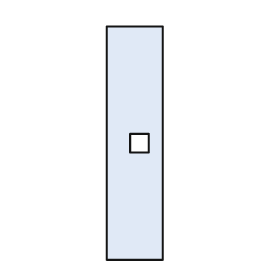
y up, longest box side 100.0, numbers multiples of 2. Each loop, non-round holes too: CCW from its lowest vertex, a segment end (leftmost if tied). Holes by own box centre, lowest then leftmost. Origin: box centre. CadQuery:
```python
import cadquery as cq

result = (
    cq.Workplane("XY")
    .moveTo(-12.0, -50.0)
    .lineTo(12.0, -50.0)
    .lineTo(12.0, 50.0)
    .lineTo(-12.0, 50.0)
    .close()
    .moveTo(-2.0, -4.0)
    .lineTo(6.0, -4.0)
    .lineTo(6.0, 4.0)
    .lineTo(-2.0, 4.0)
    .close()
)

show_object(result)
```